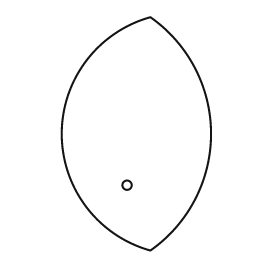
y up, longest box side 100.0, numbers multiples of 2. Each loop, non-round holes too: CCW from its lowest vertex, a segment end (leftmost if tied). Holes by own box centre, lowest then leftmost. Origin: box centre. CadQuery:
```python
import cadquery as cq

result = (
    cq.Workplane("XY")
    .moveTo(6.0, -50.0)
    .threePointArc((32.0, 0.0), (6.0, 50.0))
    .threePointArc((-32.0, 0.0), (6.0, -50.0))
    .close()
    .moveTo(-4.0, -22.0)
    .circle(2.0)
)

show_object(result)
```